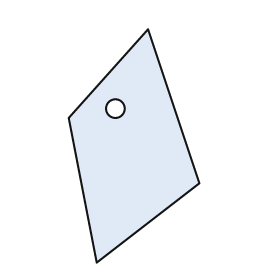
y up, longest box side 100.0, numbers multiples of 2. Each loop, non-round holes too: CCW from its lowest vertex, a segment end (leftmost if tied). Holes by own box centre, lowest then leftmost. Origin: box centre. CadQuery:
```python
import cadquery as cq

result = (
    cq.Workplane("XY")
    .moveTo(-16.0, -50.0)
    .lineTo(28.0, -16.0)
    .lineTo(6.0, 50.0)
    .lineTo(-28.0, 12.0)
    .close()
    .moveTo(-8.0, 16.0)
    .circle(4.0)
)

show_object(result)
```